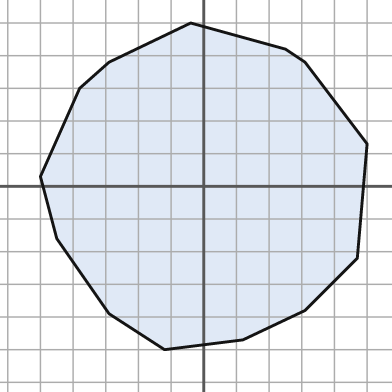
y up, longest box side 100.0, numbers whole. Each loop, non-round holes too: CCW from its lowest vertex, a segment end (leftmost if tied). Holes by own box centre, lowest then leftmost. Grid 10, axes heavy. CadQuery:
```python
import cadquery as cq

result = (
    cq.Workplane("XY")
    .moveTo(-12.0, -50.0)
    .lineTo(12.0, -47.0)
    .lineTo(31.0, -38.0)
    .lineTo(47.0, -22.0)
    .lineTo(50.0, 13.0)
    .lineTo(31.0, 38.0)
    .lineTo(25.0, 42.0)
    .lineTo(-4.0, 50.0)
    .lineTo(-29.0, 38.0)
    .lineTo(-38.0, 30.0)
    .lineTo(-50.0, 3.0)
    .lineTo(-45.0, -16.0)
    .lineTo(-29.0, -39.0)
    .close()
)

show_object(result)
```